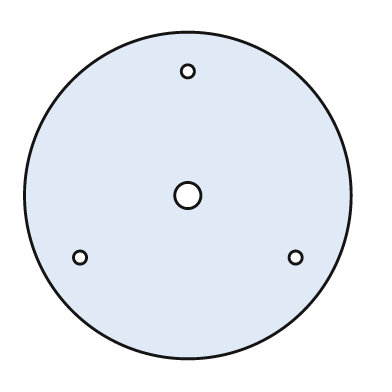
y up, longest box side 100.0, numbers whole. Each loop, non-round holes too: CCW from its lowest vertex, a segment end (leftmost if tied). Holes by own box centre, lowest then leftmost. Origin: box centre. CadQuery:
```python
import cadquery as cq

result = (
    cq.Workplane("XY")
    .moveTo(0.0, 0.0)
    .circle(50.0)
    .moveTo(-33.0, -19.0)
    .circle(2.0)
    .moveTo(33.0, -19.0)
    .circle(2.0)
    .moveTo(0.0, 0.0)
    .circle(4.0)
    .moveTo(0.0, 38.0)
    .circle(2.0)
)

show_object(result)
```